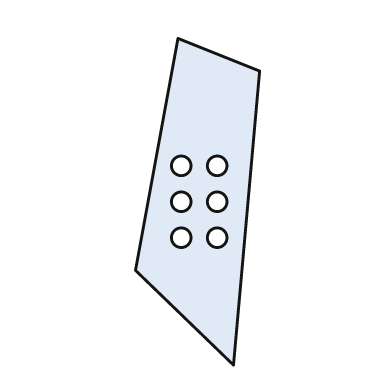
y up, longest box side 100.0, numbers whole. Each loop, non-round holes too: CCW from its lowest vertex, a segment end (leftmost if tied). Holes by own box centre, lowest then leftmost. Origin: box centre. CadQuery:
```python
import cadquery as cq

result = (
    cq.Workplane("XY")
    .moveTo(11.0, -50.0)
    .lineTo(19.0, 40.0)
    .lineTo(-6.0, 50.0)
    .lineTo(-19.0, -21.0)
    .close()
    .moveTo(-5.0, -11.0)
    .circle(3.0)
    .moveTo(6.0, -11.0)
    .circle(3.0)
    .moveTo(-5.0, 0.0)
    .circle(3.0)
    .moveTo(6.0, 0.0)
    .circle(3.0)
    .moveTo(-5.0, 11.0)
    .circle(3.0)
    .moveTo(6.0, 11.0)
    .circle(3.0)
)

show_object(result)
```